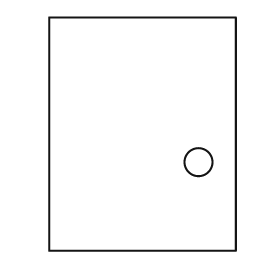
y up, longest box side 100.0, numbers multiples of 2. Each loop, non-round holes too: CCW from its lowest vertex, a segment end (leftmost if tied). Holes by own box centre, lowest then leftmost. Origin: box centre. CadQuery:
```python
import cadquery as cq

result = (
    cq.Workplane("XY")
    .moveTo(-40.0, -50.0)
    .lineTo(40.0, -50.0)
    .lineTo(40.0, 50.0)
    .lineTo(-40.0, 50.0)
    .close()
    .moveTo(24.0, -12.0)
    .circle(6.0)
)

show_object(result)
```